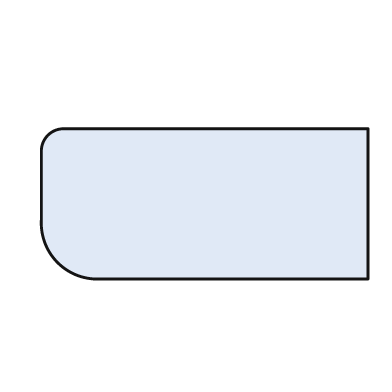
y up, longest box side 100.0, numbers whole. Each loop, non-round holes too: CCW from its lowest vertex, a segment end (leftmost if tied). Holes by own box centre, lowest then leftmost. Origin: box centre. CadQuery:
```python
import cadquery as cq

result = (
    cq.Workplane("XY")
    .moveTo(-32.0, -23.0)
    .lineTo(50.0, -23.0)
    .lineTo(50.0, 23.0)
    .lineTo(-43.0, 23.0)
    .threePointArc((-48.0, 21.0), (-50.0, 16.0))
    .lineTo(-50.0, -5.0)
    .threePointArc((-45.0, -18.0), (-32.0, -23.0))
    .close()
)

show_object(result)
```